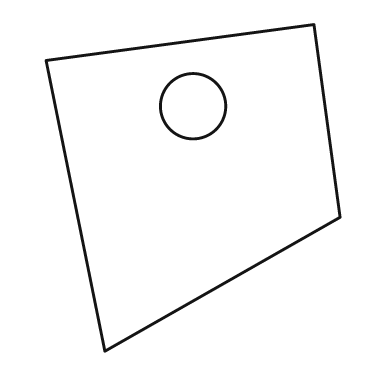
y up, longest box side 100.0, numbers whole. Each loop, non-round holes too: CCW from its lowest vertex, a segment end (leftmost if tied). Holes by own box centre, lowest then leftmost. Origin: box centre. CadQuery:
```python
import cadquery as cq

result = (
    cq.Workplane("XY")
    .moveTo(-27.0, -50.0)
    .lineTo(45.0, -9.0)
    .lineTo(37.0, 50.0)
    .lineTo(-45.0, 39.0)
    .close()
    .moveTo(0.0, 25.0)
    .circle(10.0)
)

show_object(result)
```